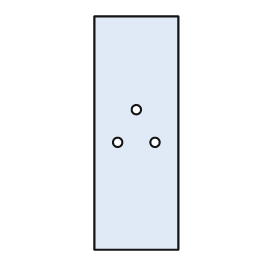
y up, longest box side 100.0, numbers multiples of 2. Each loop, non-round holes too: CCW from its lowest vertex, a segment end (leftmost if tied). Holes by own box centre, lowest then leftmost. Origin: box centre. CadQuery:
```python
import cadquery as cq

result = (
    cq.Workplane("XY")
    .moveTo(-18.0, -50.0)
    .lineTo(18.0, -50.0)
    .lineTo(18.0, 50.0)
    .lineTo(-18.0, 50.0)
    .close()
    .moveTo(-8.0, -4.0)
    .circle(2.0)
    .moveTo(8.0, -4.0)
    .circle(2.0)
    .moveTo(0.0, 10.0)
    .circle(2.0)
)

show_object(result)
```